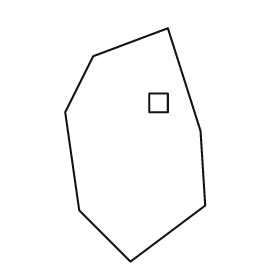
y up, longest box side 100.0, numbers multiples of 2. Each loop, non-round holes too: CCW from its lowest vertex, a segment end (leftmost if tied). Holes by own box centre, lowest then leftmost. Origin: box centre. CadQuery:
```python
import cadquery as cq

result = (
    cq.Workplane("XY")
    .moveTo(-2.0, -50.0)
    .lineTo(30.0, -26.0)
    .lineTo(28.0, 6.0)
    .lineTo(14.0, 50.0)
    .lineTo(-18.0, 38.0)
    .lineTo(-30.0, 14.0)
    .lineTo(-24.0, -28.0)
    .close()
    .moveTo(6.0, 14.0)
    .lineTo(14.0, 14.0)
    .lineTo(14.0, 22.0)
    .lineTo(6.0, 22.0)
    .close()
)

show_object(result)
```